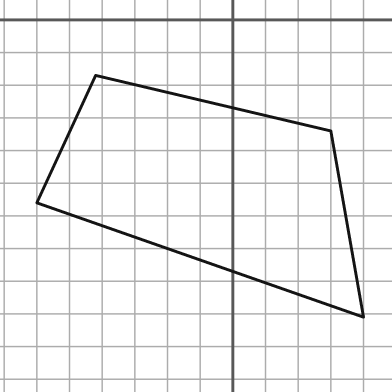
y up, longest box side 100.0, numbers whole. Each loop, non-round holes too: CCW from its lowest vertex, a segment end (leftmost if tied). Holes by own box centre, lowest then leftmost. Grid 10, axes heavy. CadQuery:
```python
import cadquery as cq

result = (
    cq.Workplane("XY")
    .moveTo(40.0, -91.0)
    .lineTo(30.0, -34.0)
    .lineTo(-42.0, -17.0)
    .lineTo(-60.0, -56.0)
    .close()
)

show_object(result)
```